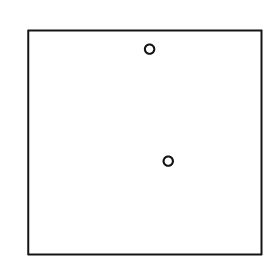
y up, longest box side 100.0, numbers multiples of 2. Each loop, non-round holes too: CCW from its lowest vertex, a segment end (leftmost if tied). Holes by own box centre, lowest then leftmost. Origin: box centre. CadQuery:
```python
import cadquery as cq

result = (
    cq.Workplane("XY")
    .moveTo(-50.0, -48.0)
    .lineTo(50.0, -48.0)
    .lineTo(50.0, 48.0)
    .lineTo(-50.0, 48.0)
    .close()
    .moveTo(10.0, -8.0)
    .circle(2.0)
    .moveTo(2.0, 40.0)
    .circle(2.0)
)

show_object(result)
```